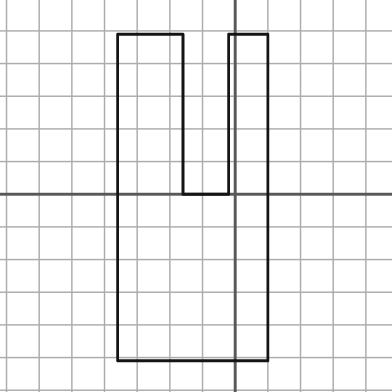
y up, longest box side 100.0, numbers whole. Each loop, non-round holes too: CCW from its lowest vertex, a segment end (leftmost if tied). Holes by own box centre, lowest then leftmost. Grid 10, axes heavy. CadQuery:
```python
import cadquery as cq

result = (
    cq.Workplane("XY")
    .moveTo(-36.0, -51.0)
    .lineTo(10.0, -51.0)
    .lineTo(10.0, 49.0)
    .lineTo(-2.0, 49.0)
    .lineTo(-2.0, 0.0)
    .lineTo(-16.0, 0.0)
    .lineTo(-16.0, 49.0)
    .lineTo(-36.0, 49.0)
    .close()
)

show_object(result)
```